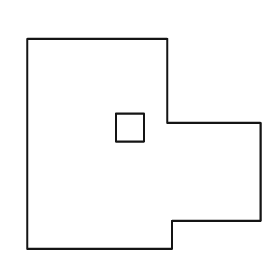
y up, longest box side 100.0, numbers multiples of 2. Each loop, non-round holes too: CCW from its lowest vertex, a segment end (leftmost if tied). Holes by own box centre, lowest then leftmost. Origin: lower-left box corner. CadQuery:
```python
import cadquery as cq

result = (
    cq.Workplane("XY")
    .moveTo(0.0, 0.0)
    .lineTo(62.0, 0.0)
    .lineTo(62.0, 12.0)
    .lineTo(100.0, 12.0)
    .lineTo(100.0, 54.0)
    .lineTo(60.0, 54.0)
    .lineTo(60.0, 90.0)
    .lineTo(0.0, 90.0)
    .close()
    .moveTo(38.0, 46.0)
    .lineTo(50.0, 46.0)
    .lineTo(50.0, 58.0)
    .lineTo(38.0, 58.0)
    .close()
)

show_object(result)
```